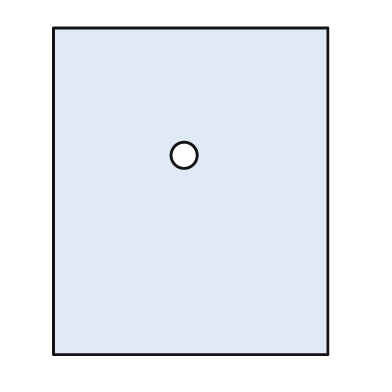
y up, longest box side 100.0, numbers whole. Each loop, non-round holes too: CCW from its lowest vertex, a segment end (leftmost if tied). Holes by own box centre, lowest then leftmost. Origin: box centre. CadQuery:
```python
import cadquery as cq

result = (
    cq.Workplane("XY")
    .moveTo(-42.0, -50.0)
    .lineTo(42.0, -50.0)
    .lineTo(42.0, 50.0)
    .lineTo(-42.0, 50.0)
    .close()
    .moveTo(-2.0, 11.0)
    .circle(4.0)
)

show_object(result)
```